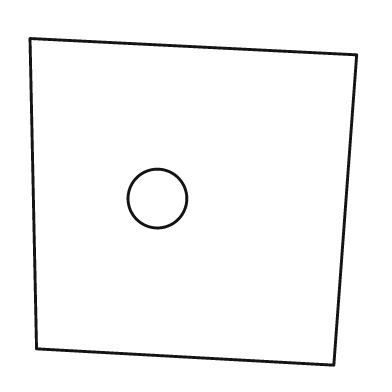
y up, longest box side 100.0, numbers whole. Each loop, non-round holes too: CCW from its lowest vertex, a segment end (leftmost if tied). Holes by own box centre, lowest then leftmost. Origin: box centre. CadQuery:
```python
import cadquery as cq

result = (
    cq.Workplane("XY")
    .moveTo(43.0, -50.0)
    .lineTo(50.0, 45.0)
    .lineTo(-50.0, 50.0)
    .lineTo(-48.0, -45.0)
    .close()
    .moveTo(-11.0, 1.0)
    .circle(9.0)
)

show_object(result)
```